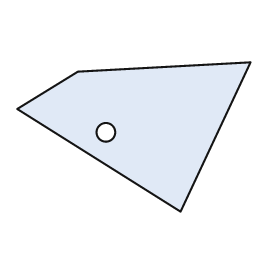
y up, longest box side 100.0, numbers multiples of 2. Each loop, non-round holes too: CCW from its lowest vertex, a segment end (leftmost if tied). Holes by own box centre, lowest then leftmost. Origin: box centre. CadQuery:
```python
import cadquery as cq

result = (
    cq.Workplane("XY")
    .moveTo(20.0, -32.0)
    .lineTo(50.0, 32.0)
    .lineTo(-24.0, 28.0)
    .lineTo(-50.0, 12.0)
    .close()
    .moveTo(-12.0, 2.0)
    .circle(4.0)
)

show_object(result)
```